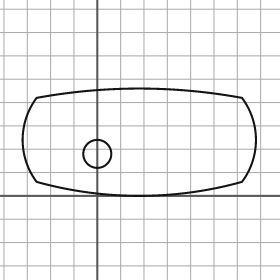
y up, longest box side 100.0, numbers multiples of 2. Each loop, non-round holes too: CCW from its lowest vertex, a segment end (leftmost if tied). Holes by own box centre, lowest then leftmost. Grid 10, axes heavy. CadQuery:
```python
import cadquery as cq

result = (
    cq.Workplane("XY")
    .moveTo(-26.0, 6.0)
    .threePointArc((18.0, 0.0), (62.0, 6.0))
    .threePointArc((68.0, 24.0), (62.0, 42.0))
    .threePointArc((18.0, 46.0), (-26.0, 42.0))
    .threePointArc((-32.0, 24.0), (-26.0, 6.0))
    .close()
    .moveTo(0.0, 18.0)
    .circle(6.0)
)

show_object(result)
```